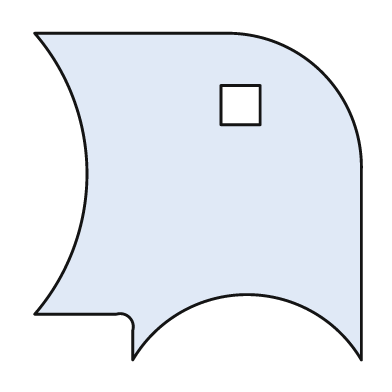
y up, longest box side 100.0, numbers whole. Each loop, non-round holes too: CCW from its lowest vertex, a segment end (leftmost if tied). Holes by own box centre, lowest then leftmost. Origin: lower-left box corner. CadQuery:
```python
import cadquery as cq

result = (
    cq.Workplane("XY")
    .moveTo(30.0, 0.0)
    .threePointArc((65.0, 20.0), (100.0, 0.0))
    .lineTo(100.0, 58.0)
    .threePointArc((88.0, 88.0), (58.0, 100.0))
    .lineTo(0.0, 100.0)
    .threePointArc((16.0, 57.0), (0.0, 14.0))
    .lineTo(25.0, 14.0)
    .threePointArc((29.0, 13.0), (30.0, 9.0))
    .close()
    .moveTo(57.0, 72.0)
    .lineTo(69.0, 72.0)
    .lineTo(69.0, 84.0)
    .lineTo(57.0, 84.0)
    .close()
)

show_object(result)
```